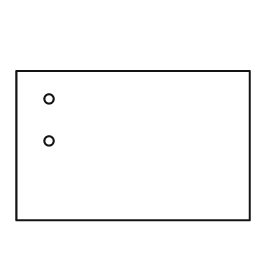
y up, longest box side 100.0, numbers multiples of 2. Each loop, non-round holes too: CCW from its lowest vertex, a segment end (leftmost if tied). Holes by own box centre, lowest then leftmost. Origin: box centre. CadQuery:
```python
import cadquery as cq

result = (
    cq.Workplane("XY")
    .moveTo(-50.0, -32.0)
    .lineTo(50.0, -32.0)
    .lineTo(50.0, 32.0)
    .lineTo(-50.0, 32.0)
    .close()
    .moveTo(-36.0, 2.0)
    .circle(2.0)
    .moveTo(-36.0, 20.0)
    .circle(2.0)
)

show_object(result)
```